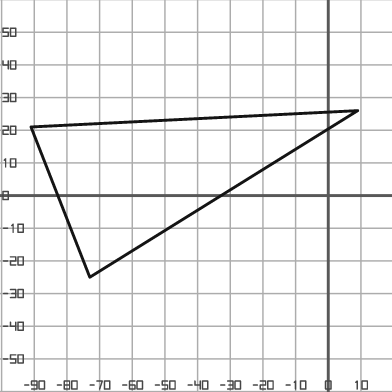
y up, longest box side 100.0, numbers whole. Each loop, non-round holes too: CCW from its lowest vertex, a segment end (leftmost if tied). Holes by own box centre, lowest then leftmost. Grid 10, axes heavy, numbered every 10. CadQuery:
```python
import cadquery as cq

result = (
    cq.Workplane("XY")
    .moveTo(-73.0, -25.0)
    .lineTo(9.0, 26.0)
    .lineTo(-91.0, 21.0)
    .close()
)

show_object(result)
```